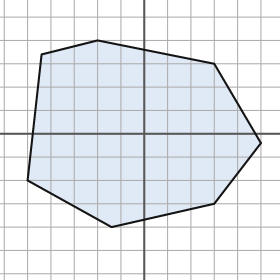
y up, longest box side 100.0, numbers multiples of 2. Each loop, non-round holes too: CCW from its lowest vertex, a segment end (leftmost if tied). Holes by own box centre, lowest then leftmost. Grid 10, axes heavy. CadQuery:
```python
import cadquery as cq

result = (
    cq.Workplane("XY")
    .moveTo(-14.0, -40.0)
    .lineTo(30.0, -30.0)
    .lineTo(50.0, -4.0)
    .lineTo(30.0, 30.0)
    .lineTo(-20.0, 40.0)
    .lineTo(-44.0, 34.0)
    .lineTo(-50.0, -20.0)
    .close()
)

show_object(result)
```